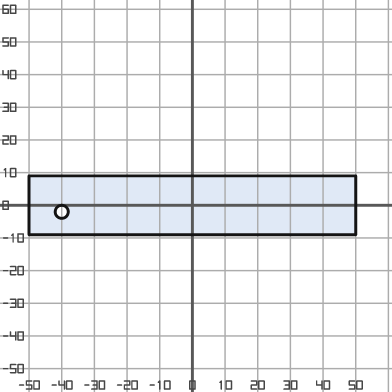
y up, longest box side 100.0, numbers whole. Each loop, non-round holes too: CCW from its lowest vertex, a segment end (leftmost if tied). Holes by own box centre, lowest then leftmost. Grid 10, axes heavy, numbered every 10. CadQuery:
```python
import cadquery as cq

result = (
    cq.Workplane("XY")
    .moveTo(-50.0, -9.0)
    .lineTo(50.0, -9.0)
    .lineTo(50.0, 9.0)
    .lineTo(-50.0, 9.0)
    .close()
    .moveTo(-40.0, -2.0)
    .circle(2.0)
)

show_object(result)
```